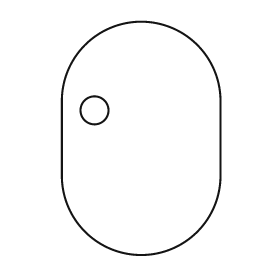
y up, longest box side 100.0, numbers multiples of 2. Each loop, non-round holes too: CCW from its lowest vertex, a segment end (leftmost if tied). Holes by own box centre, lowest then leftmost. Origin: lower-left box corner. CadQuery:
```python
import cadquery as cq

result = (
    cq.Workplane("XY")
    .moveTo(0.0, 34.0)
    .threePointArc((34.0, 0.0), (68.0, 34.0))
    .lineTo(68.0, 66.0)
    .threePointArc((34.0, 100.0), (0.0, 66.0))
    .close()
    .moveTo(14.0, 62.0)
    .circle(6.0)
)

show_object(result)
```